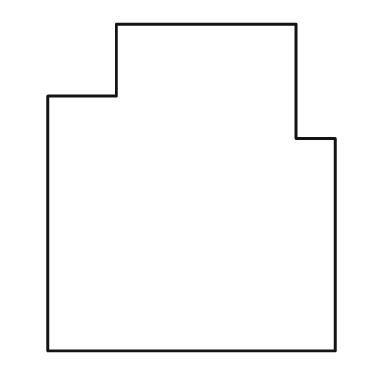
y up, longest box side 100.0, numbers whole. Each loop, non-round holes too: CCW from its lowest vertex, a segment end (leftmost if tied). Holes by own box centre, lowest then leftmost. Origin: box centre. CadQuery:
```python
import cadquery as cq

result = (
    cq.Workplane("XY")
    .moveTo(-44.0, -50.0)
    .lineTo(44.0, -50.0)
    .lineTo(44.0, 15.0)
    .lineTo(32.0, 15.0)
    .lineTo(32.0, 50.0)
    .lineTo(-23.0, 50.0)
    .lineTo(-23.0, 28.0)
    .lineTo(-44.0, 28.0)
    .close()
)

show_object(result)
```